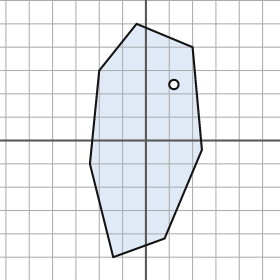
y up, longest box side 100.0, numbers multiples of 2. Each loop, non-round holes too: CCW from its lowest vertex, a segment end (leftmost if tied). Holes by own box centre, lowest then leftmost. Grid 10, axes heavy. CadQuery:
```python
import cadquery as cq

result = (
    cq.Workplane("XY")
    .moveTo(-14.0, -50.0)
    .lineTo(8.0, -42.0)
    .lineTo(24.0, -4.0)
    .lineTo(20.0, 40.0)
    .lineTo(-4.0, 50.0)
    .lineTo(-20.0, 30.0)
    .lineTo(-24.0, -10.0)
    .close()
    .moveTo(12.0, 24.0)
    .circle(2.0)
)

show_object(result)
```